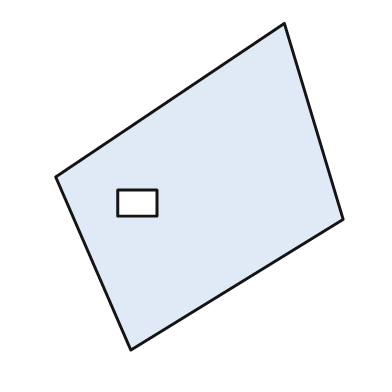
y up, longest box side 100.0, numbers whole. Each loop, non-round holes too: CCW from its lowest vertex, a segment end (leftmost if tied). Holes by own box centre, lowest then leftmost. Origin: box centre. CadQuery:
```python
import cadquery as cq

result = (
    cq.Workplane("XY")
    .moveTo(-21.0, -50.0)
    .lineTo(44.0, -10.0)
    .lineTo(26.0, 50.0)
    .lineTo(-44.0, 3.0)
    .close()
    .moveTo(-25.0, -9.0)
    .lineTo(-13.0, -9.0)
    .lineTo(-13.0, -1.0)
    .lineTo(-25.0, -1.0)
    .close()
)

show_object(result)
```